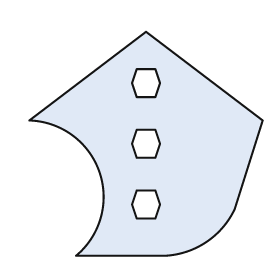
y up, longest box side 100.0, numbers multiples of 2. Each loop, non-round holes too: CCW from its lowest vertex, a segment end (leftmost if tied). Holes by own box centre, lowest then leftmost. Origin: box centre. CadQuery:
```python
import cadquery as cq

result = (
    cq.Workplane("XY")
    .moveTo(-30.0, -48.0)
    .lineTo(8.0, -48.0)
    .threePointArc((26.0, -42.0), (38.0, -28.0))
    .lineTo(50.0, 10.0)
    .lineTo(0.0, 48.0)
    .lineTo(-50.0, 10.0)
    .threePointArc((-20.0, -12.0), (-30.0, -48.0))
    .close()
    .moveTo(-4.0, -32.0)
    .lineTo(4.0, -32.0)
    .lineTo(6.0, -26.0)
    .lineTo(4.0, -20.0)
    .lineTo(-4.0, -20.0)
    .lineTo(-6.0, -26.0)
    .close()
    .moveTo(-4.0, -6.0)
    .lineTo(4.0, -6.0)
    .lineTo(6.0, 0.0)
    .lineTo(4.0, 6.0)
    .lineTo(-4.0, 6.0)
    .lineTo(-6.0, 0.0)
    .close()
    .moveTo(-4.0, 20.0)
    .lineTo(4.0, 20.0)
    .lineTo(6.0, 26.0)
    .lineTo(4.0, 32.0)
    .lineTo(-4.0, 32.0)
    .lineTo(-6.0, 26.0)
    .close()
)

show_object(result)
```